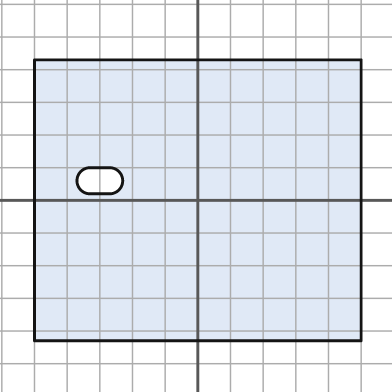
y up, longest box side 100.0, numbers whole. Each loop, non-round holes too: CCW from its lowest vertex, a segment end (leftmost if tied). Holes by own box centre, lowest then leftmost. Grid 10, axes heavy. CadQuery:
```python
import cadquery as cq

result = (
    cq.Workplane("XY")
    .moveTo(-50.0, -43.0)
    .lineTo(50.0, -43.0)
    .lineTo(50.0, 43.0)
    .lineTo(-50.0, 43.0)
    .close()
    .moveTo(-33.0, 2.0)
    .lineTo(-27.0, 2.0)
    .threePointArc((-23.0, 6.0), (-27.0, 10.0))
    .lineTo(-33.0, 10.0)
    .threePointArc((-37.0, 6.0), (-33.0, 2.0))
    .close()
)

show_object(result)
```